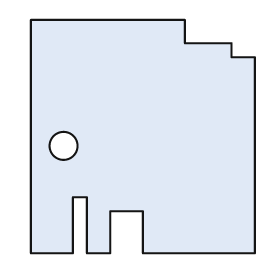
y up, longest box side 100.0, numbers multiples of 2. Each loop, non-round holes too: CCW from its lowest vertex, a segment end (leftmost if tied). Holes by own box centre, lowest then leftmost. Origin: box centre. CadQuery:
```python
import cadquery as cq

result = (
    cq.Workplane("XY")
    .moveTo(-48.0, -50.0)
    .lineTo(-30.0, -50.0)
    .lineTo(-30.0, -26.0)
    .lineTo(-24.0, -26.0)
    .lineTo(-24.0, -50.0)
    .lineTo(-14.0, -50.0)
    .lineTo(-14.0, -32.0)
    .lineTo(0.0, -32.0)
    .lineTo(0.0, -50.0)
    .lineTo(48.0, -50.0)
    .lineTo(48.0, 34.0)
    .lineTo(38.0, 34.0)
    .lineTo(38.0, 40.0)
    .lineTo(18.0, 40.0)
    .lineTo(18.0, 50.0)
    .lineTo(-48.0, 50.0)
    .close()
    .moveTo(-34.0, -4.0)
    .circle(6.0)
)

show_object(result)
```